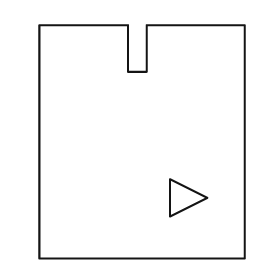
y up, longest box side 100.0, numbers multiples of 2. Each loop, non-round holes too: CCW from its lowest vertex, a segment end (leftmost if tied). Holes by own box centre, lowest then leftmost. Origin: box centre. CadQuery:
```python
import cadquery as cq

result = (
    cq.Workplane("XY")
    .moveTo(-44.0, -50.0)
    .lineTo(44.0, -50.0)
    .lineTo(44.0, 50.0)
    .lineTo(2.0, 50.0)
    .lineTo(2.0, 30.0)
    .lineTo(-6.0, 30.0)
    .lineTo(-6.0, 50.0)
    .lineTo(-44.0, 50.0)
    .close()
    .moveTo(12.0, -32.0)
    .lineTo(28.0, -24.0)
    .lineTo(12.0, -16.0)
    .close()
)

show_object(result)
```